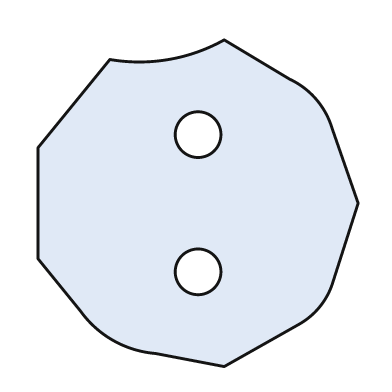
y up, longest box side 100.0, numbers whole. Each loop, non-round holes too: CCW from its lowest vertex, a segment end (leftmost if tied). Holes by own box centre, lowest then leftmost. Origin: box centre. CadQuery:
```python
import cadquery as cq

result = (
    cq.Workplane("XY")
    .moveTo(8.0, -50.0)
    .lineTo(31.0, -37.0)
    .threePointArc((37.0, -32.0), (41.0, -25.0))
    .lineTo(49.0, 0.0)
    .lineTo(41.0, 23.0)
    .threePointArc((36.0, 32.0), (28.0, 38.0))
    .lineTo(8.0, 50.0)
    .threePointArc((-9.0, 44.0), (-27.0, 44.0))
    .lineTo(-49.0, 17.0)
    .lineTo(-49.0, -17.0)
    .lineTo(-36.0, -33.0)
    .threePointArc((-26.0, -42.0), (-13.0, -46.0))
    .close()
    .moveTo(0.0, -21.0)
    .circle(7.0)
    .moveTo(0.0, 21.0)
    .circle(7.0)
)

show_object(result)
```